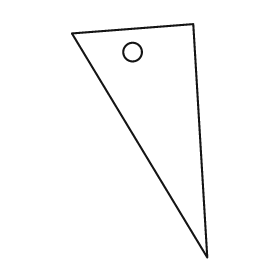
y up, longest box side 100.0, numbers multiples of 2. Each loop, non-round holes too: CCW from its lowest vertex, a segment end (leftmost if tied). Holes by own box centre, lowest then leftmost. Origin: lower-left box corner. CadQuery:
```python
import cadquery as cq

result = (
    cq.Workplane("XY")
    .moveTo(58.0, 0.0)
    .lineTo(52.0, 100.0)
    .lineTo(0.0, 96.0)
    .close()
    .moveTo(26.0, 88.0)
    .circle(4.0)
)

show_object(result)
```